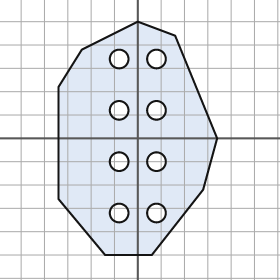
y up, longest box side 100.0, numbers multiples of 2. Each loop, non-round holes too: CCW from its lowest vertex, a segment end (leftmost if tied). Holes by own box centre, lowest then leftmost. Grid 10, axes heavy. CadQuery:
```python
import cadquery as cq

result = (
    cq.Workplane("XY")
    .moveTo(-14.0, -50.0)
    .lineTo(6.0, -50.0)
    .lineTo(28.0, -22.0)
    .lineTo(34.0, 0.0)
    .lineTo(16.0, 44.0)
    .lineTo(0.0, 50.0)
    .lineTo(-24.0, 38.0)
    .lineTo(-34.0, 22.0)
    .lineTo(-34.0, -26.0)
    .close()
    .moveTo(-8.0, -32.0)
    .circle(4.0)
    .moveTo(8.0, -32.0)
    .circle(4.0)
    .moveTo(-8.0, -10.0)
    .circle(4.0)
    .moveTo(8.0, -10.0)
    .circle(4.0)
    .moveTo(-8.0, 12.0)
    .circle(4.0)
    .moveTo(8.0, 12.0)
    .circle(4.0)
    .moveTo(-8.0, 34.0)
    .circle(4.0)
    .moveTo(8.0, 34.0)
    .circle(4.0)
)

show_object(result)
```